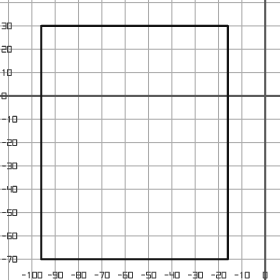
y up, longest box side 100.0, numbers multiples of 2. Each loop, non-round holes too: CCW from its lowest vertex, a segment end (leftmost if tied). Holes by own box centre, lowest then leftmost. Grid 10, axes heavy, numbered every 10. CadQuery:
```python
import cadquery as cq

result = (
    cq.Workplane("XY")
    .moveTo(-96.0, -70.0)
    .lineTo(-16.0, -70.0)
    .lineTo(-16.0, 30.0)
    .lineTo(-96.0, 30.0)
    .close()
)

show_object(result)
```